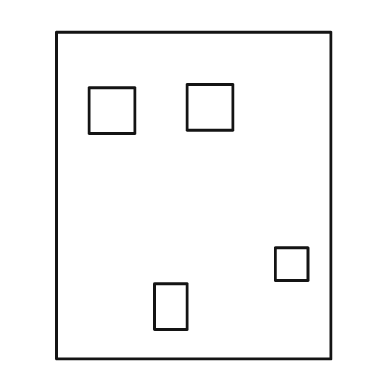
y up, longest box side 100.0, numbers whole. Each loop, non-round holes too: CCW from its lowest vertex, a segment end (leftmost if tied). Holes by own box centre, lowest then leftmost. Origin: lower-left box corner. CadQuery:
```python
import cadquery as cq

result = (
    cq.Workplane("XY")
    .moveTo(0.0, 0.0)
    .lineTo(84.0, 0.0)
    .lineTo(84.0, 100.0)
    .lineTo(0.0, 100.0)
    .close()
    .moveTo(30.0, 9.0)
    .lineTo(40.0, 9.0)
    .lineTo(40.0, 23.0)
    .lineTo(30.0, 23.0)
    .close()
    .moveTo(67.0, 24.0)
    .lineTo(77.0, 24.0)
    .lineTo(77.0, 34.0)
    .lineTo(67.0, 34.0)
    .close()
    .moveTo(10.0, 69.0)
    .lineTo(24.0, 69.0)
    .lineTo(24.0, 83.0)
    .lineTo(10.0, 83.0)
    .close()
    .moveTo(40.0, 70.0)
    .lineTo(54.0, 70.0)
    .lineTo(54.0, 84.0)
    .lineTo(40.0, 84.0)
    .close()
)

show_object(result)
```